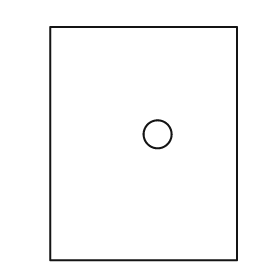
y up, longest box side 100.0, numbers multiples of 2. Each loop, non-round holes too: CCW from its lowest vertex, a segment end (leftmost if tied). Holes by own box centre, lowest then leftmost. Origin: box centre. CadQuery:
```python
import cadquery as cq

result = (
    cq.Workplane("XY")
    .moveTo(-40.0, -50.0)
    .lineTo(40.0, -50.0)
    .lineTo(40.0, 50.0)
    .lineTo(-40.0, 50.0)
    .close()
    .moveTo(6.0, 4.0)
    .circle(6.0)
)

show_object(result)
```